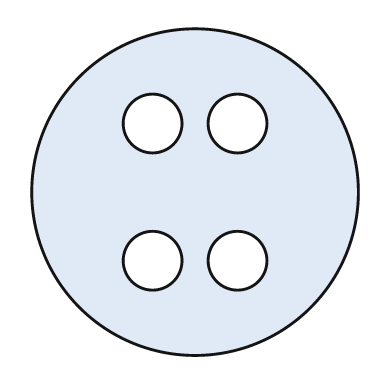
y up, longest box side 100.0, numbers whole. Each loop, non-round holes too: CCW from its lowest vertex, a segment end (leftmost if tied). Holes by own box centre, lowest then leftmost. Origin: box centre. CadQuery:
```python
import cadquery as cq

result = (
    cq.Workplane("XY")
    .moveTo(0.0, 0.0)
    .circle(50.0)
    .moveTo(-13.0, -21.0)
    .circle(9.0)
    .moveTo(13.0, -21.0)
    .circle(9.0)
    .moveTo(-13.0, 21.0)
    .circle(9.0)
    .moveTo(13.0, 21.0)
    .circle(9.0)
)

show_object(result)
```